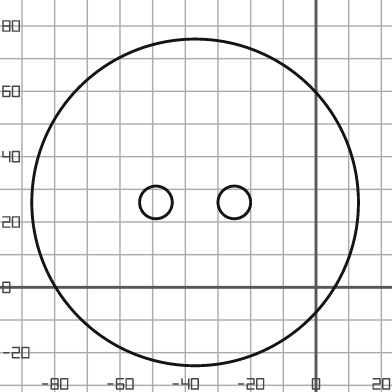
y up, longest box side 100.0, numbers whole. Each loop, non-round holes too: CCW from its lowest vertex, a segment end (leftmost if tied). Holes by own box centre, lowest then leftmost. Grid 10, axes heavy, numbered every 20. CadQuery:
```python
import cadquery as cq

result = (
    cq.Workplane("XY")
    .moveTo(-37.0, 26.0)
    .circle(50.0)
    .moveTo(-49.0, 26.0)
    .circle(5.0)
    .moveTo(-25.0, 26.0)
    .circle(5.0)
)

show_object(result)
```